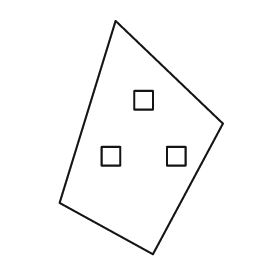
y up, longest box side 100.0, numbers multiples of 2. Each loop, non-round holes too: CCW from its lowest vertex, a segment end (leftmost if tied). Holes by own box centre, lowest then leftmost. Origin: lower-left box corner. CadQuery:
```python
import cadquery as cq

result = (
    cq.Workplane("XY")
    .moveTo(40.0, 0.0)
    .lineTo(70.0, 56.0)
    .lineTo(24.0, 100.0)
    .lineTo(0.0, 22.0)
    .close()
    .moveTo(18.0, 38.0)
    .lineTo(26.0, 38.0)
    .lineTo(26.0, 46.0)
    .lineTo(18.0, 46.0)
    .close()
    .moveTo(46.0, 38.0)
    .lineTo(54.0, 38.0)
    .lineTo(54.0, 46.0)
    .lineTo(46.0, 46.0)
    .close()
    .moveTo(32.0, 62.0)
    .lineTo(40.0, 62.0)
    .lineTo(40.0, 70.0)
    .lineTo(32.0, 70.0)
    .close()
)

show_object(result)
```